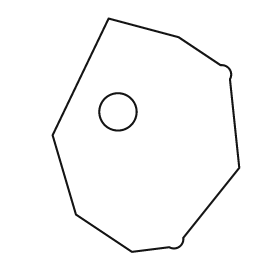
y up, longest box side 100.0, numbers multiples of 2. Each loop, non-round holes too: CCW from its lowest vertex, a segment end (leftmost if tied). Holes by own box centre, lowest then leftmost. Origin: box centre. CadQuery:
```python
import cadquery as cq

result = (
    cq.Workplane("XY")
    .moveTo(-6.0, -50.0)
    .lineTo(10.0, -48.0)
    .threePointArc((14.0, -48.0), (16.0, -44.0))
    .lineTo(40.0, -14.0)
    .lineTo(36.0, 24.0)
    .threePointArc((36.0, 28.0), (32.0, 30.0))
    .lineTo(14.0, 42.0)
    .lineTo(-16.0, 50.0)
    .lineTo(-40.0, 0.0)
    .lineTo(-30.0, -34.0)
    .close()
    .moveTo(-12.0, 10.0)
    .circle(8.0)
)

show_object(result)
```